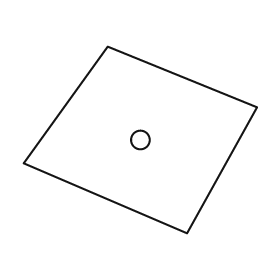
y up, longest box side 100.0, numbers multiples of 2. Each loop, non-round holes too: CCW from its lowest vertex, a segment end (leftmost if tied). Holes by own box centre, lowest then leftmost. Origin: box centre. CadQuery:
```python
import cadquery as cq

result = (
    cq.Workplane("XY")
    .moveTo(20.0, -40.0)
    .lineTo(50.0, 14.0)
    .lineTo(-14.0, 40.0)
    .lineTo(-50.0, -10.0)
    .close()
    .moveTo(0.0, 0.0)
    .circle(4.0)
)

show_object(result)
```